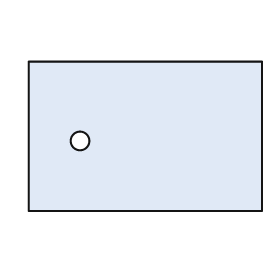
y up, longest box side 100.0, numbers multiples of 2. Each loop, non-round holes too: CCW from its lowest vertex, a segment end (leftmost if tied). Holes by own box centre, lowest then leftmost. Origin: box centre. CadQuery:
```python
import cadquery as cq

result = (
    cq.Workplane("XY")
    .moveTo(-50.0, -32.0)
    .lineTo(50.0, -32.0)
    .lineTo(50.0, 32.0)
    .lineTo(-50.0, 32.0)
    .close()
    .moveTo(-28.0, -2.0)
    .circle(4.0)
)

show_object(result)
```